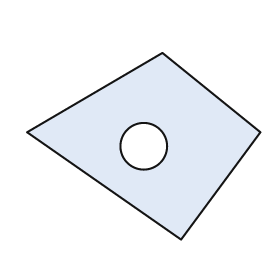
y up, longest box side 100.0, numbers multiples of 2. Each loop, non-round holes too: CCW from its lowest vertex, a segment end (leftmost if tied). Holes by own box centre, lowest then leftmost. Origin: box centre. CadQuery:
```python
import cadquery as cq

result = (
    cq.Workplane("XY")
    .moveTo(16.0, -40.0)
    .lineTo(50.0, 6.0)
    .lineTo(8.0, 40.0)
    .lineTo(-50.0, 6.0)
    .close()
    .moveTo(0.0, 0.0)
    .circle(10.0)
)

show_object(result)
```